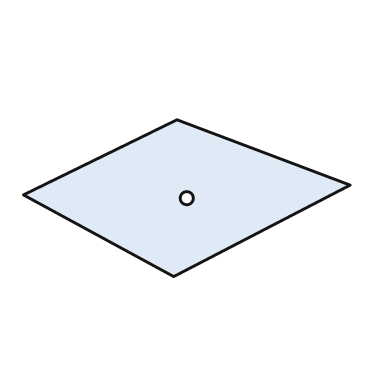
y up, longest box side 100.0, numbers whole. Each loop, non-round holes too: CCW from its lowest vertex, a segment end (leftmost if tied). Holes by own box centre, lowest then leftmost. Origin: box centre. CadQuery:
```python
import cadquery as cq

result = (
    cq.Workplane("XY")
    .moveTo(-4.0, -24.0)
    .lineTo(50.0, 4.0)
    .lineTo(-3.0, 24.0)
    .lineTo(-50.0, 1.0)
    .close()
    .moveTo(0.0, 0.0)
    .circle(2.0)
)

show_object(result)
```